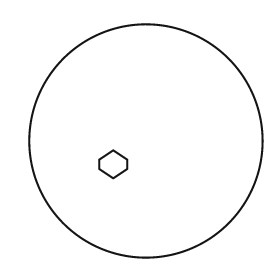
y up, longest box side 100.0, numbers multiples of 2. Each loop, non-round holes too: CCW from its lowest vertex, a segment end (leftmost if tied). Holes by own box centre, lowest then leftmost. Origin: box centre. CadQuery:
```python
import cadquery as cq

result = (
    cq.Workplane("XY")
    .moveTo(0.0, 0.0)
    .circle(50.0)
    .moveTo(-14.0, -16.0)
    .lineTo(-8.0, -12.0)
    .lineTo(-8.0, -8.0)
    .lineTo(-14.0, -4.0)
    .lineTo(-20.0, -8.0)
    .lineTo(-20.0, -12.0)
    .close()
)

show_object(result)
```